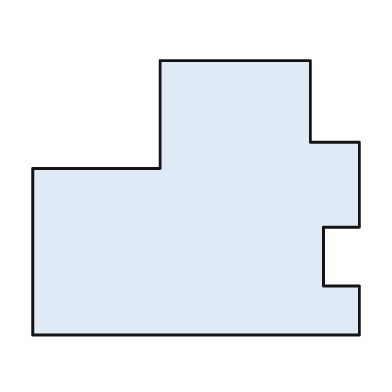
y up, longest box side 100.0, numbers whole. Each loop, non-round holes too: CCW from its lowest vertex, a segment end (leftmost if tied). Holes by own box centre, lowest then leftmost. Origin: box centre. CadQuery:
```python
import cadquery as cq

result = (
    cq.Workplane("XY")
    .moveTo(-50.0, -42.0)
    .lineTo(50.0, -42.0)
    .lineTo(50.0, -27.0)
    .lineTo(39.0, -27.0)
    .lineTo(39.0, -9.0)
    .lineTo(50.0, -9.0)
    .lineTo(50.0, 17.0)
    .lineTo(35.0, 17.0)
    .lineTo(35.0, 42.0)
    .lineTo(-11.0, 42.0)
    .lineTo(-11.0, 9.0)
    .lineTo(-50.0, 9.0)
    .close()
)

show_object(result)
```